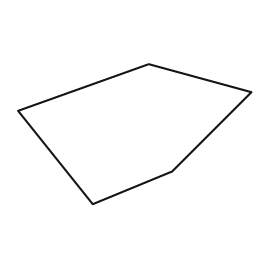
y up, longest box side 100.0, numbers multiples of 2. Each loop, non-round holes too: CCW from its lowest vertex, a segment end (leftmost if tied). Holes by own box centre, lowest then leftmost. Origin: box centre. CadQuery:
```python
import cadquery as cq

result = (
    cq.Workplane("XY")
    .moveTo(-18.0, -30.0)
    .lineTo(16.0, -16.0)
    .lineTo(50.0, 18.0)
    .lineTo(6.0, 30.0)
    .lineTo(-50.0, 10.0)
    .close()
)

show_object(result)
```